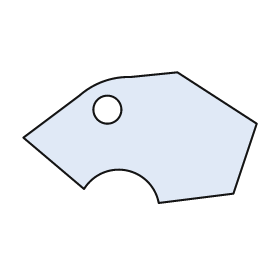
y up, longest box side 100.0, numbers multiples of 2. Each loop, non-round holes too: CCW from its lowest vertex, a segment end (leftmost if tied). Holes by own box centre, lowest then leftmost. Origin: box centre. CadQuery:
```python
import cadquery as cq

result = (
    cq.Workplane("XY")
    .moveTo(8.0, -28.0)
    .lineTo(40.0, -24.0)
    .lineTo(50.0, 6.0)
    .lineTo(16.0, 28.0)
    .lineTo(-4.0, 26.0)
    .threePointArc((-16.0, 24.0), (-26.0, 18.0))
    .lineTo(-50.0, 0.0)
    .lineTo(-24.0, -22.0)
    .threePointArc((-6.0, -14.0), (8.0, -28.0))
    .close()
    .moveTo(-14.0, 12.0)
    .circle(6.0)
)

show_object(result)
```